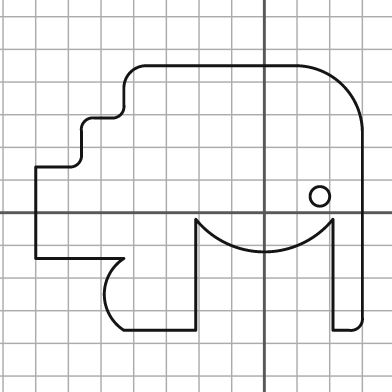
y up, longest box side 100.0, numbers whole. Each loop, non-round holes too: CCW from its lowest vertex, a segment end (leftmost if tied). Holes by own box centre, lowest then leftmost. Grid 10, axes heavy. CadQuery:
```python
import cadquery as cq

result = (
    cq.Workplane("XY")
    .moveTo(-43.0, -36.0)
    .lineTo(-21.0, -36.0)
    .lineTo(-21.0, -2.0)
    .threePointArc((0.0, -12.0), (21.0, -2.0))
    .lineTo(21.0, -36.0)
    .lineTo(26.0, -36.0)
    .threePointArc((29.0, -35.0), (30.0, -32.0))
    .lineTo(30.0, 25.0)
    .threePointArc((24.0, 39.0), (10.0, 45.0))
    .lineTo(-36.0, 45.0)
    .threePointArc((-41.0, 43.0), (-43.0, 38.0))
    .lineTo(-43.0, 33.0)
    .threePointArc((-44.0, 30.0), (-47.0, 29.0))
    .lineTo(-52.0, 29.0)
    .threePointArc((-55.0, 28.0), (-56.0, 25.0))
    .lineTo(-56.0, 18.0)
    .threePointArc((-57.0, 15.0), (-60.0, 14.0))
    .lineTo(-70.0, 14.0)
    .lineTo(-70.0, -14.0)
    .lineTo(-43.0, -14.0)
    .threePointArc((-49.0, -25.0), (-43.0, -36.0))
    .close()
    .moveTo(17.0, 5.0)
    .circle(3.0)
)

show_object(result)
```